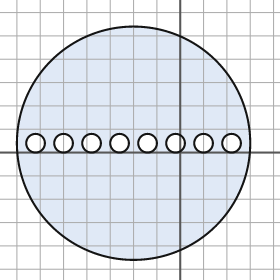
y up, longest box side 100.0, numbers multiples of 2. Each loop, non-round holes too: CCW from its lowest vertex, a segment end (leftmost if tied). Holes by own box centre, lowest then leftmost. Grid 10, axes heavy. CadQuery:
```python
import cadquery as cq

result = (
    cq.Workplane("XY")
    .moveTo(-20.0, 4.0)
    .circle(50.0)
    .moveTo(-62.0, 4.0)
    .circle(4.0)
    .moveTo(-50.0, 4.0)
    .circle(4.0)
    .moveTo(-38.0, 4.0)
    .circle(4.0)
    .moveTo(-26.0, 4.0)
    .circle(4.0)
    .moveTo(-14.0, 4.0)
    .circle(4.0)
    .moveTo(-2.0, 4.0)
    .circle(4.0)
    .moveTo(10.0, 4.0)
    .circle(4.0)
    .moveTo(22.0, 4.0)
    .circle(4.0)
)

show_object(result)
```